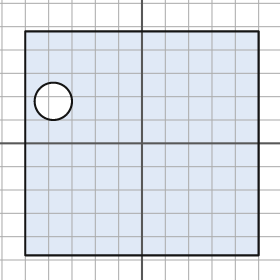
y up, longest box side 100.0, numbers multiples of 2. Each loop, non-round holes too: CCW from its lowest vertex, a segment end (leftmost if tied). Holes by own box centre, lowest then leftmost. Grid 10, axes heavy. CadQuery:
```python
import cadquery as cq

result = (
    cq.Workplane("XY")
    .moveTo(-50.0, -48.0)
    .lineTo(50.0, -48.0)
    .lineTo(50.0, 48.0)
    .lineTo(-50.0, 48.0)
    .close()
    .moveTo(-38.0, 18.0)
    .circle(8.0)
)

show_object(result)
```